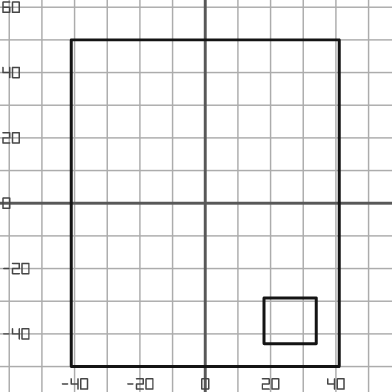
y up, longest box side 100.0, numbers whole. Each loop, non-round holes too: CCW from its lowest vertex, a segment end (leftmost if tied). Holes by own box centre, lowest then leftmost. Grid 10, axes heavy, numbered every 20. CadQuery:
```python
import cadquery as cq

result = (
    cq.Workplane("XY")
    .moveTo(-41.0, -50.0)
    .lineTo(41.0, -50.0)
    .lineTo(41.0, 50.0)
    .lineTo(-41.0, 50.0)
    .close()
    .moveTo(18.0, -43.0)
    .lineTo(34.0, -43.0)
    .lineTo(34.0, -29.0)
    .lineTo(18.0, -29.0)
    .close()
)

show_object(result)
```